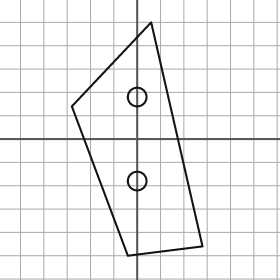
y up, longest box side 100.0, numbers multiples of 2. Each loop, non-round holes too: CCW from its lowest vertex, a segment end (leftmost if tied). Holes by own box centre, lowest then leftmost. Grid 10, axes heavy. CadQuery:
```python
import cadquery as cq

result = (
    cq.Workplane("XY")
    .moveTo(-4.0, -50.0)
    .lineTo(28.0, -46.0)
    .lineTo(6.0, 50.0)
    .lineTo(-28.0, 14.0)
    .close()
    .moveTo(0.0, -18.0)
    .circle(4.0)
    .moveTo(0.0, 18.0)
    .circle(4.0)
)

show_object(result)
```